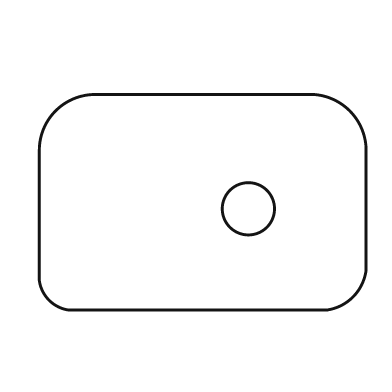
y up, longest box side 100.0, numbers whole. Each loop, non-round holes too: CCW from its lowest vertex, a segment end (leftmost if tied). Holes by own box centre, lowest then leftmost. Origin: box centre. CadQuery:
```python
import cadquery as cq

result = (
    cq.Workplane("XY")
    .moveTo(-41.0, -33.0)
    .lineTo(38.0, -33.0)
    .threePointArc((46.0, -29.0), (50.0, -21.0))
    .lineTo(50.0, 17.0)
    .threePointArc((45.0, 28.0), (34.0, 33.0))
    .lineTo(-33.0, 33.0)
    .threePointArc((-45.0, 28.0), (-50.0, 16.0))
    .lineTo(-50.0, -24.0)
    .threePointArc((-47.0, -30.0), (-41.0, -33.0))
    .close()
    .moveTo(14.0, -2.0)
    .circle(8.0)
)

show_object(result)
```